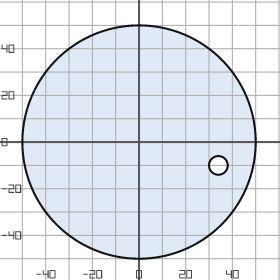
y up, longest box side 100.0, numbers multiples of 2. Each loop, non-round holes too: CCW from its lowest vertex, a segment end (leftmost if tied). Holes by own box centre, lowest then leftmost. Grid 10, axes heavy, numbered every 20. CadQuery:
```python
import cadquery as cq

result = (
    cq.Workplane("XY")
    .moveTo(0.0, 0.0)
    .circle(50.0)
    .moveTo(34.0, -10.0)
    .circle(4.0)
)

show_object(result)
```